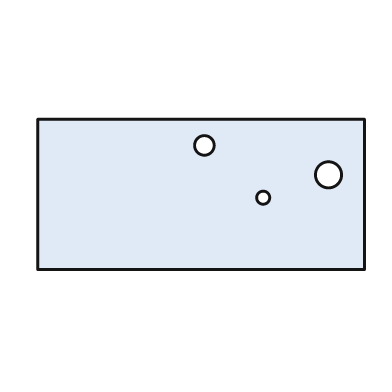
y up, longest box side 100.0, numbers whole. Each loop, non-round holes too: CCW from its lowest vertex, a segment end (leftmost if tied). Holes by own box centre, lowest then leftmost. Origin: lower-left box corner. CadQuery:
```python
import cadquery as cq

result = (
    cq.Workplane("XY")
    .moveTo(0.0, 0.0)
    .lineTo(100.0, 0.0)
    .lineTo(100.0, 46.0)
    .lineTo(0.0, 46.0)
    .close()
    .moveTo(69.0, 22.0)
    .circle(2.0)
    .moveTo(89.0, 29.0)
    .circle(4.0)
    .moveTo(51.0, 38.0)
    .circle(3.0)
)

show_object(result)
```